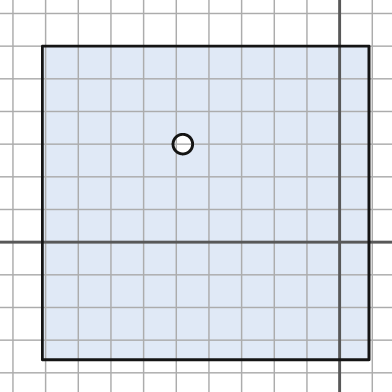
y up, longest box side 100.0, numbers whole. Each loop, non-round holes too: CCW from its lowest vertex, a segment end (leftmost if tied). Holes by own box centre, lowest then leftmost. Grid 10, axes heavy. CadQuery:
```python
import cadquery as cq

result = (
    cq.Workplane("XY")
    .moveTo(-91.0, -36.0)
    .lineTo(9.0, -36.0)
    .lineTo(9.0, 60.0)
    .lineTo(-91.0, 60.0)
    .close()
    .moveTo(-48.0, 30.0)
    .circle(3.0)
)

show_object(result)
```